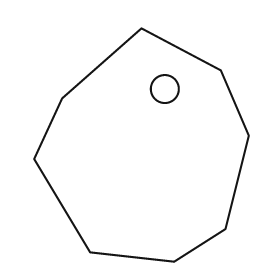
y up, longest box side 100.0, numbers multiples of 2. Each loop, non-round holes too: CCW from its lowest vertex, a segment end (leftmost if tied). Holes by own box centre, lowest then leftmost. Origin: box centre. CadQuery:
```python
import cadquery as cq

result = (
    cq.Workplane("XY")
    .moveTo(14.0, -50.0)
    .lineTo(36.0, -36.0)
    .lineTo(46.0, 4.0)
    .lineTo(34.0, 32.0)
    .lineTo(0.0, 50.0)
    .lineTo(-34.0, 20.0)
    .lineTo(-46.0, -6.0)
    .lineTo(-22.0, -46.0)
    .close()
    .moveTo(10.0, 24.0)
    .circle(6.0)
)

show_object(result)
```